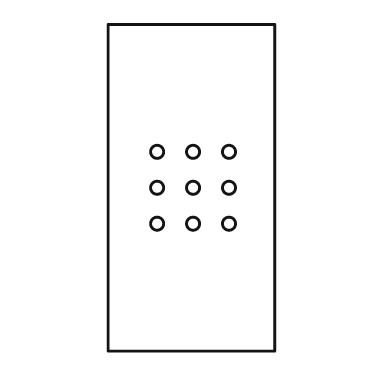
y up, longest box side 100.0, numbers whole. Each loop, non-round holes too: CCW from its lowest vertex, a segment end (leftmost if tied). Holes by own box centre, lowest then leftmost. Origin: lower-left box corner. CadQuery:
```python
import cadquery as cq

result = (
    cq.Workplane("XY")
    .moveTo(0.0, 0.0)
    .lineTo(51.0, 0.0)
    .lineTo(51.0, 100.0)
    .lineTo(0.0, 100.0)
    .close()
    .moveTo(15.0, 39.0)
    .circle(2.0)
    .moveTo(26.0, 39.0)
    .circle(2.0)
    .moveTo(37.0, 39.0)
    .circle(2.0)
    .moveTo(15.0, 50.0)
    .circle(2.0)
    .moveTo(26.0, 50.0)
    .circle(2.0)
    .moveTo(37.0, 50.0)
    .circle(2.0)
    .moveTo(15.0, 61.0)
    .circle(2.0)
    .moveTo(26.0, 61.0)
    .circle(2.0)
    .moveTo(37.0, 61.0)
    .circle(2.0)
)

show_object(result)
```